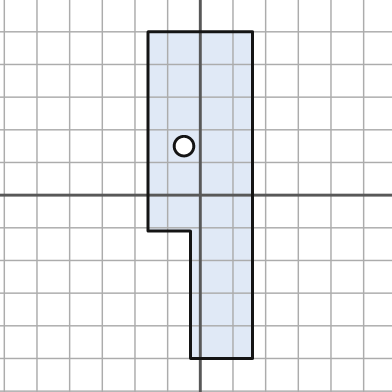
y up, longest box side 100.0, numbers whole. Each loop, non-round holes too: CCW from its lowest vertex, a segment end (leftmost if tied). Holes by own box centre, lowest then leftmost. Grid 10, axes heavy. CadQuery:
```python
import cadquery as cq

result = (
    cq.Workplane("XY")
    .moveTo(-3.0, -50.0)
    .lineTo(16.0, -50.0)
    .lineTo(16.0, 50.0)
    .lineTo(-16.0, 50.0)
    .lineTo(-16.0, -11.0)
    .lineTo(-3.0, -11.0)
    .close()
    .moveTo(-5.0, 15.0)
    .circle(3.0)
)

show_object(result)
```